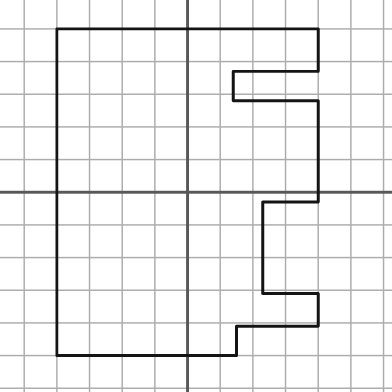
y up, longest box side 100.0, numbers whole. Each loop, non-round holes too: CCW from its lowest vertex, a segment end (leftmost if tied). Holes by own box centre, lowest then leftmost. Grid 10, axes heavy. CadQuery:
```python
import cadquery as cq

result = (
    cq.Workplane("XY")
    .moveTo(-40.0, -50.0)
    .lineTo(15.0, -50.0)
    .lineTo(15.0, -41.0)
    .lineTo(40.0, -41.0)
    .lineTo(40.0, -31.0)
    .lineTo(23.0, -31.0)
    .lineTo(23.0, -3.0)
    .lineTo(40.0, -3.0)
    .lineTo(40.0, 28.0)
    .lineTo(14.0, 28.0)
    .lineTo(14.0, 37.0)
    .lineTo(40.0, 37.0)
    .lineTo(40.0, 50.0)
    .lineTo(-40.0, 50.0)
    .close()
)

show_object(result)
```